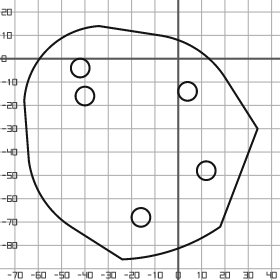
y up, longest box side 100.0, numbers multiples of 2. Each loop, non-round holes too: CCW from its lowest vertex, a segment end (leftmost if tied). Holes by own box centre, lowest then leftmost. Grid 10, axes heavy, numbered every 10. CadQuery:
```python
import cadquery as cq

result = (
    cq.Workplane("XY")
    .moveTo(-24.0, -86.0)
    .threePointArc((-2.0, -82.0), (18.0, -72.0))
    .lineTo(34.0, -30.0)
    .lineTo(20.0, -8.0)
    .threePointArc((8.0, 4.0), (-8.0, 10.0))
    .lineTo(-34.0, 14.0)
    .threePointArc((-56.0, 4.0), (-66.0, -18.0))
    .lineTo(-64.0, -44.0)
    .threePointArc((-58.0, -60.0), (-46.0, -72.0))
    .close()
    .moveTo(-16.0, -68.0)
    .circle(4.0)
    .moveTo(12.0, -48.0)
    .circle(4.0)
    .moveTo(-40.0, -16.0)
    .circle(4.0)
    .moveTo(4.0, -14.0)
    .circle(4.0)
    .moveTo(-42.0, -4.0)
    .circle(4.0)
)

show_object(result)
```